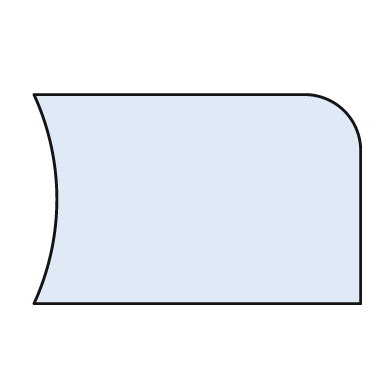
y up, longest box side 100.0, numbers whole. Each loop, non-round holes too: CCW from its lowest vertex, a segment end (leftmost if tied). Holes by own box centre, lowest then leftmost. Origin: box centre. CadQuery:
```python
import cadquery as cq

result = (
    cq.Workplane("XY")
    .moveTo(-50.0, -32.0)
    .lineTo(50.0, -32.0)
    .lineTo(50.0, 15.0)
    .threePointArc((45.0, 27.0), (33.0, 32.0))
    .lineTo(-50.0, 32.0)
    .threePointArc((-43.0, 0.0), (-50.0, -32.0))
    .close()
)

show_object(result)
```